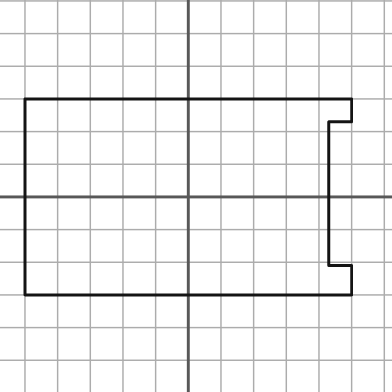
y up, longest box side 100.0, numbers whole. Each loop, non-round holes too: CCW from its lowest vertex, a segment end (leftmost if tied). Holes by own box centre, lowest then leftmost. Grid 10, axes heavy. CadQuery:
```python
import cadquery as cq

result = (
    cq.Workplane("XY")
    .moveTo(-50.0, -30.0)
    .lineTo(50.0, -30.0)
    .lineTo(50.0, -21.0)
    .lineTo(43.0, -21.0)
    .lineTo(43.0, 23.0)
    .lineTo(50.0, 23.0)
    .lineTo(50.0, 30.0)
    .lineTo(-50.0, 30.0)
    .close()
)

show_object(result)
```